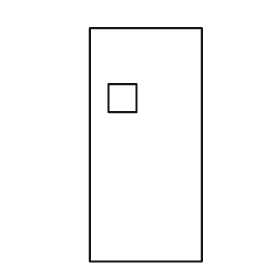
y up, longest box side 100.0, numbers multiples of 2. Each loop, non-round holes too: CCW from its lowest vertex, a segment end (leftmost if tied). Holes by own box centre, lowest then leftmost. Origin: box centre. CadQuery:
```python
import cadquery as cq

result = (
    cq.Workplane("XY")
    .moveTo(-24.0, -50.0)
    .lineTo(24.0, -50.0)
    .lineTo(24.0, 50.0)
    .lineTo(-24.0, 50.0)
    .close()
    .moveTo(-16.0, 14.0)
    .lineTo(-4.0, 14.0)
    .lineTo(-4.0, 26.0)
    .lineTo(-16.0, 26.0)
    .close()
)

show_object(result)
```